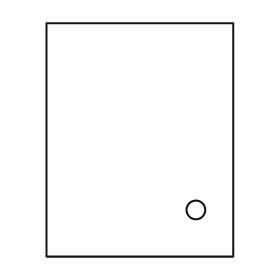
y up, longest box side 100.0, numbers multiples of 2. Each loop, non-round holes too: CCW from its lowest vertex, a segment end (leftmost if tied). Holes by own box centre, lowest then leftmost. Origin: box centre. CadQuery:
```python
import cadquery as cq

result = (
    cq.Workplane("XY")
    .moveTo(-40.0, -50.0)
    .lineTo(40.0, -50.0)
    .lineTo(40.0, 50.0)
    .lineTo(-40.0, 50.0)
    .close()
    .moveTo(24.0, -30.0)
    .circle(4.0)
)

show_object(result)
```